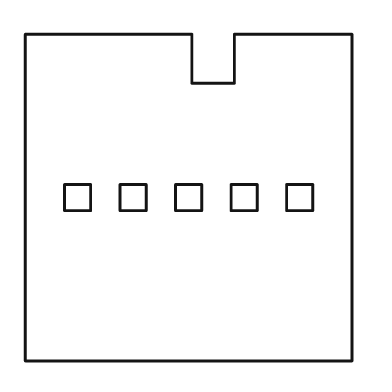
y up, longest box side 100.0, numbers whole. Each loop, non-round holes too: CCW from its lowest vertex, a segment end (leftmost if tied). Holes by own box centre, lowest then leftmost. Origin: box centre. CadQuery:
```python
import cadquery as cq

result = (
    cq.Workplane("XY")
    .moveTo(-50.0, -50.0)
    .lineTo(50.0, -50.0)
    .lineTo(50.0, 50.0)
    .lineTo(14.0, 50.0)
    .lineTo(14.0, 35.0)
    .lineTo(1.0, 35.0)
    .lineTo(1.0, 50.0)
    .lineTo(-50.0, 50.0)
    .close()
    .moveTo(-38.0, -4.0)
    .lineTo(-30.0, -4.0)
    .lineTo(-30.0, 4.0)
    .lineTo(-38.0, 4.0)
    .close()
    .moveTo(-21.0, -4.0)
    .lineTo(-13.0, -4.0)
    .lineTo(-13.0, 4.0)
    .lineTo(-21.0, 4.0)
    .close()
    .moveTo(-4.0, -4.0)
    .lineTo(4.0, -4.0)
    .lineTo(4.0, 4.0)
    .lineTo(-4.0, 4.0)
    .close()
    .moveTo(13.0, -4.0)
    .lineTo(21.0, -4.0)
    .lineTo(21.0, 4.0)
    .lineTo(13.0, 4.0)
    .close()
    .moveTo(30.0, -4.0)
    .lineTo(38.0, -4.0)
    .lineTo(38.0, 4.0)
    .lineTo(30.0, 4.0)
    .close()
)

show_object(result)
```